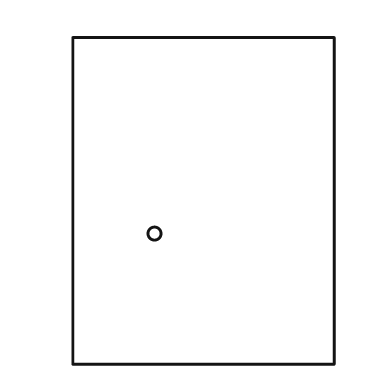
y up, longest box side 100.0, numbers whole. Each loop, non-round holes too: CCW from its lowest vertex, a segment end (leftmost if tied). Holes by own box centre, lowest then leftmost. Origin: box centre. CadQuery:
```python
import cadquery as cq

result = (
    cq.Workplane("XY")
    .moveTo(-40.0, -50.0)
    .lineTo(40.0, -50.0)
    .lineTo(40.0, 50.0)
    .lineTo(-40.0, 50.0)
    .close()
    .moveTo(-15.0, -10.0)
    .circle(2.0)
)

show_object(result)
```